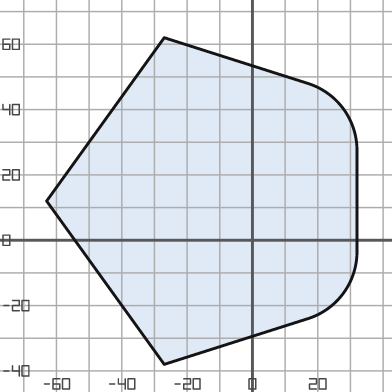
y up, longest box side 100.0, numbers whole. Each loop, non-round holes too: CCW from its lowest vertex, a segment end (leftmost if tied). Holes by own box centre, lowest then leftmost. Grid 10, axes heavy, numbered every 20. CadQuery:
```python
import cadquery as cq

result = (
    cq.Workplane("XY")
    .moveTo(-27.0, -38.0)
    .lineTo(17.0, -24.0)
    .threePointArc((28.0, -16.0), (32.0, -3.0))
    .lineTo(32.0, 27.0)
    .threePointArc((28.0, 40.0), (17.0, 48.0))
    .lineTo(-27.0, 62.0)
    .lineTo(-63.0, 12.0)
    .close()
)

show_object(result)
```